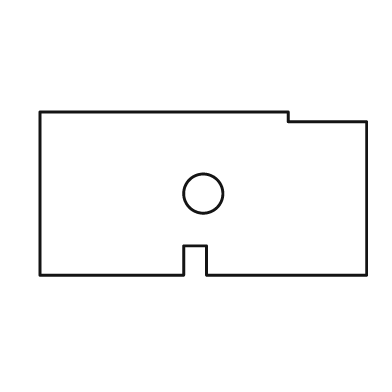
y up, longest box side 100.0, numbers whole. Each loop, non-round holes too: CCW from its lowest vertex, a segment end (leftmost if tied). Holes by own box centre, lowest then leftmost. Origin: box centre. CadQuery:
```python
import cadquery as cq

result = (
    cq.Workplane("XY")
    .moveTo(-50.0, -25.0)
    .lineTo(-6.0, -25.0)
    .lineTo(-6.0, -16.0)
    .lineTo(1.0, -16.0)
    .lineTo(1.0, -25.0)
    .lineTo(50.0, -25.0)
    .lineTo(50.0, 22.0)
    .lineTo(26.0, 22.0)
    .lineTo(26.0, 25.0)
    .lineTo(-50.0, 25.0)
    .close()
    .moveTo(0.0, 0.0)
    .circle(6.0)
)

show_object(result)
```